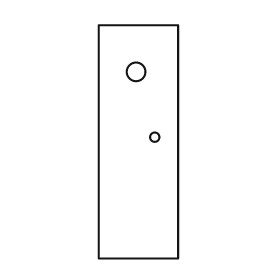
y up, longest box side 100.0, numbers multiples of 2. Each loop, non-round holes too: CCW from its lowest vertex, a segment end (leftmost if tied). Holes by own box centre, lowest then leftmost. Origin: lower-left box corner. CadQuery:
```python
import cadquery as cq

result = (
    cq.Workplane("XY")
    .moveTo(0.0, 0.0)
    .lineTo(34.0, 0.0)
    .lineTo(34.0, 100.0)
    .lineTo(0.0, 100.0)
    .close()
    .moveTo(24.0, 52.0)
    .circle(2.0)
    .moveTo(16.0, 80.0)
    .circle(4.0)
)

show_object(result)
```